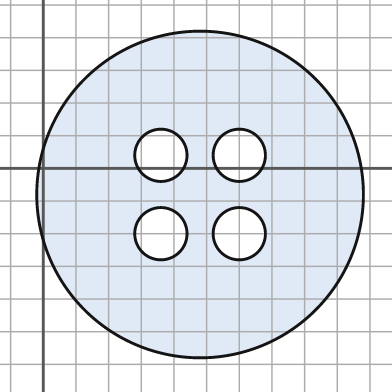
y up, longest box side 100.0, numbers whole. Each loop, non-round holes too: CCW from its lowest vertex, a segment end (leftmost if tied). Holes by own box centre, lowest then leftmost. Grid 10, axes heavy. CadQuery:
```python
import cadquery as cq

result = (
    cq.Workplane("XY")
    .moveTo(48.0, -8.0)
    .circle(50.0)
    .moveTo(36.0, -20.0)
    .circle(8.0)
    .moveTo(60.0, -20.0)
    .circle(8.0)
    .moveTo(36.0, 4.0)
    .circle(8.0)
    .moveTo(60.0, 4.0)
    .circle(8.0)
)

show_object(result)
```